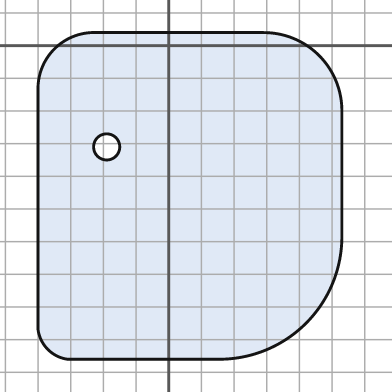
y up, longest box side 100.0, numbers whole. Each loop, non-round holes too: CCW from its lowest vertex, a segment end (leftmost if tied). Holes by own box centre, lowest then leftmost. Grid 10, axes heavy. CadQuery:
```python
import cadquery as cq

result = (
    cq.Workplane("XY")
    .moveTo(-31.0, -96.0)
    .lineTo(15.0, -96.0)
    .threePointArc((42.0, -85.0), (53.0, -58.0))
    .lineTo(53.0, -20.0)
    .threePointArc((46.0, -3.0), (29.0, 4.0))
    .lineTo(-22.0, 4.0)
    .threePointArc((-35.0, -1.0), (-40.0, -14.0))
    .lineTo(-40.0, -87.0)
    .threePointArc((-37.0, -93.0), (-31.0, -96.0))
    .close()
    .moveTo(-19.0, -31.0)
    .circle(4.0)
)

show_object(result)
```